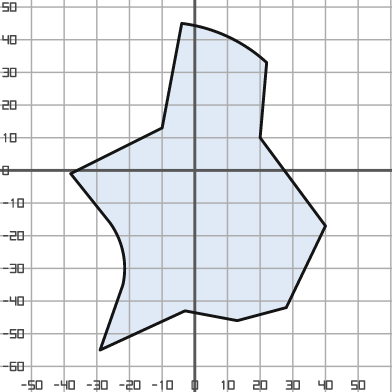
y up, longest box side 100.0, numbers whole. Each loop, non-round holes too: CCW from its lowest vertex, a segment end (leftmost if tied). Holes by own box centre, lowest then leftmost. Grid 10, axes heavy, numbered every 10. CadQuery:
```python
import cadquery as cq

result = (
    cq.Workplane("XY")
    .moveTo(-29.0, -55.0)
    .lineTo(-3.0, -43.0)
    .lineTo(13.0, -46.0)
    .lineTo(28.0, -42.0)
    .lineTo(40.0, -17.0)
    .lineTo(20.0, 10.0)
    .lineTo(22.0, 33.0)
    .threePointArc((10.0, 41.0), (-4.0, 45.0))
    .lineTo(-10.0, 13.0)
    .lineTo(-38.0, -1.0)
    .lineTo(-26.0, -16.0)
    .threePointArc((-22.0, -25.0), (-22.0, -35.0))
    .close()
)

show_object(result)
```